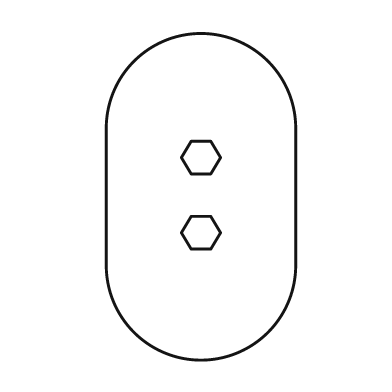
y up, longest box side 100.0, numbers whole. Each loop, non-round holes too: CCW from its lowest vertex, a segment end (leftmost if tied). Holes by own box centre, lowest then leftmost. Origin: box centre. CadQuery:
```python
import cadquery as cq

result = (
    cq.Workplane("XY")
    .moveTo(-29.0, -21.0)
    .threePointArc((0.0, -50.0), (29.0, -21.0))
    .lineTo(29.0, 21.0)
    .threePointArc((0.0, 50.0), (-29.0, 21.0))
    .close()
    .moveTo(-3.0, -16.0)
    .lineTo(3.0, -16.0)
    .lineTo(6.0, -11.0)
    .lineTo(3.0, -6.0)
    .lineTo(-3.0, -6.0)
    .lineTo(-6.0, -11.0)
    .close()
    .moveTo(-3.0, 7.0)
    .lineTo(3.0, 7.0)
    .lineTo(6.0, 12.0)
    .lineTo(3.0, 17.0)
    .lineTo(-3.0, 17.0)
    .lineTo(-6.0, 12.0)
    .close()
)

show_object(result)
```